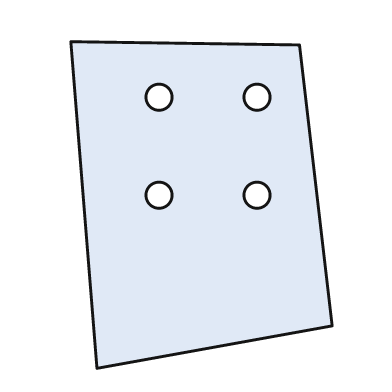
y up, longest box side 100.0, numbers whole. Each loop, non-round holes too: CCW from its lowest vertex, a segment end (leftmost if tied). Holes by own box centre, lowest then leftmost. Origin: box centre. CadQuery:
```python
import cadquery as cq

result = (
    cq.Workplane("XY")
    .moveTo(-32.0, -50.0)
    .lineTo(40.0, -37.0)
    .lineTo(30.0, 49.0)
    .lineTo(-40.0, 50.0)
    .close()
    .moveTo(-13.0, 3.0)
    .circle(4.0)
    .moveTo(17.0, 3.0)
    .circle(4.0)
    .moveTo(-13.0, 33.0)
    .circle(4.0)
    .moveTo(17.0, 33.0)
    .circle(4.0)
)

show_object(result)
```